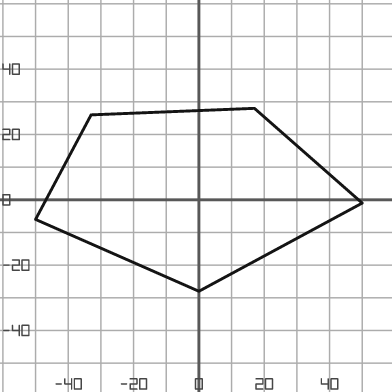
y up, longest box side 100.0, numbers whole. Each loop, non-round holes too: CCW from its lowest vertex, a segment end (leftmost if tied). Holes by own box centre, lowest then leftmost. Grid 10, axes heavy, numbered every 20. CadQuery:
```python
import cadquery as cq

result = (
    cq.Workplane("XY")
    .moveTo(0.0, -28.0)
    .lineTo(50.0, -1.0)
    .lineTo(17.0, 28.0)
    .lineTo(-33.0, 26.0)
    .lineTo(-50.0, -6.0)
    .close()
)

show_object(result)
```